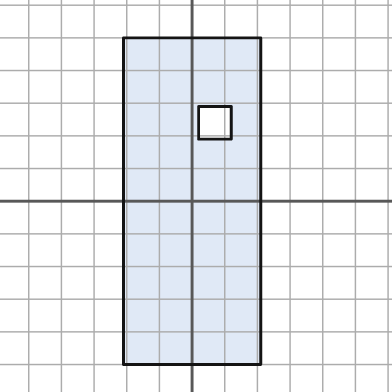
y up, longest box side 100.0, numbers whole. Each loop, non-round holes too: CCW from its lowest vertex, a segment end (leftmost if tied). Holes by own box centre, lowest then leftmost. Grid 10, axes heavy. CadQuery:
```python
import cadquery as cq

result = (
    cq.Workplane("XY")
    .moveTo(-21.0, -50.0)
    .lineTo(21.0, -50.0)
    .lineTo(21.0, 50.0)
    .lineTo(-21.0, 50.0)
    .close()
    .moveTo(2.0, 19.0)
    .lineTo(12.0, 19.0)
    .lineTo(12.0, 29.0)
    .lineTo(2.0, 29.0)
    .close()
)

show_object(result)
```